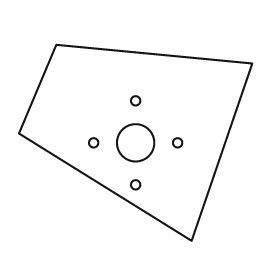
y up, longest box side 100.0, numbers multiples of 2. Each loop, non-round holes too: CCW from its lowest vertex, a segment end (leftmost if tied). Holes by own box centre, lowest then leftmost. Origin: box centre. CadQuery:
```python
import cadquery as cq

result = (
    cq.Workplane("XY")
    .moveTo(24.0, -42.0)
    .lineTo(50.0, 34.0)
    .lineTo(-34.0, 42.0)
    .lineTo(-50.0, 4.0)
    .close()
    .moveTo(0.0, -18.0)
    .circle(2.0)
    .moveTo(-18.0, 0.0)
    .circle(2.0)
    .moveTo(0.0, 0.0)
    .circle(8.0)
    .moveTo(18.0, 0.0)
    .circle(2.0)
    .moveTo(0.0, 18.0)
    .circle(2.0)
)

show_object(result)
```